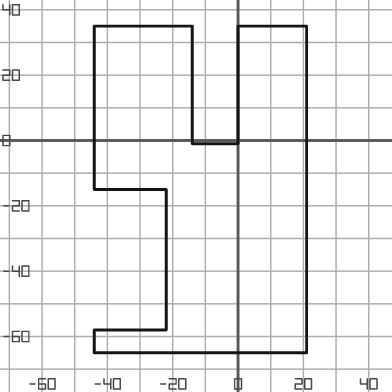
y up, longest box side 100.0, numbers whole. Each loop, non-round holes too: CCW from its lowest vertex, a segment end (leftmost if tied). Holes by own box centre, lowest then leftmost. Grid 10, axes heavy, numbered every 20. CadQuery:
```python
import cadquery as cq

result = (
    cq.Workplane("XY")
    .moveTo(-44.0, -65.0)
    .lineTo(21.0, -65.0)
    .lineTo(21.0, 35.0)
    .lineTo(0.0, 35.0)
    .lineTo(0.0, -1.0)
    .lineTo(-14.0, -1.0)
    .lineTo(-14.0, 35.0)
    .lineTo(-44.0, 35.0)
    .lineTo(-44.0, -15.0)
    .lineTo(-22.0, -15.0)
    .lineTo(-22.0, -58.0)
    .lineTo(-44.0, -58.0)
    .close()
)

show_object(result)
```